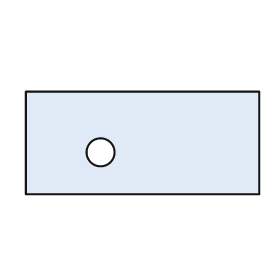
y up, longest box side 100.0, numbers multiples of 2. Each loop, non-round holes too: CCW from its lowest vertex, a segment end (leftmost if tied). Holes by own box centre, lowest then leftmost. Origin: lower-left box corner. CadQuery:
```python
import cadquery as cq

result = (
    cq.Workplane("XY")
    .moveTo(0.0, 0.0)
    .lineTo(100.0, 0.0)
    .lineTo(100.0, 44.0)
    .lineTo(0.0, 44.0)
    .close()
    .moveTo(32.0, 18.0)
    .circle(6.0)
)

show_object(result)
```